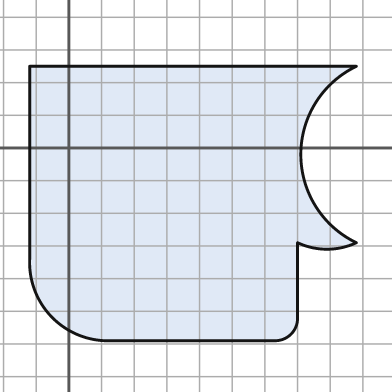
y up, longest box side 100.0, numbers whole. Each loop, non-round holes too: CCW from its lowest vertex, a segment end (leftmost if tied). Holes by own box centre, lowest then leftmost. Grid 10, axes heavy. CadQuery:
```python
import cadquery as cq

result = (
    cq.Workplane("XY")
    .moveTo(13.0, -59.0)
    .lineTo(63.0, -59.0)
    .threePointArc((68.0, -57.0), (70.0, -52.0))
    .lineTo(70.0, -29.0)
    .threePointArc((79.0, -31.0), (88.0, -29.0))
    .threePointArc((71.0, -2.0), (88.0, 25.0))
    .lineTo(-12.0, 25.0)
    .lineTo(-12.0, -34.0)
    .threePointArc((-5.0, -52.0), (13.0, -59.0))
    .close()
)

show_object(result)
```